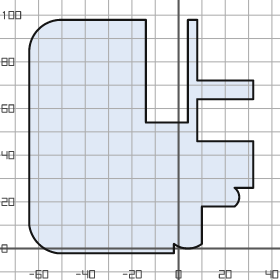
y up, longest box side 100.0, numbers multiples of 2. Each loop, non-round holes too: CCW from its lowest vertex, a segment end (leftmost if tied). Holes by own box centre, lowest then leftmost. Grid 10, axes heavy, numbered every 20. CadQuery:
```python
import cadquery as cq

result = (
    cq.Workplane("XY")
    .moveTo(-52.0, -2.0)
    .lineTo(-2.0, -2.0)
    .lineTo(-2.0, 2.0)
    .threePointArc((4.0, 0.0), (10.0, 2.0))
    .lineTo(10.0, 18.0)
    .lineTo(24.0, 18.0)
    .threePointArc((26.0, 22.0), (24.0, 26.0))
    .lineTo(32.0, 26.0)
    .lineTo(32.0, 46.0)
    .lineTo(8.0, 46.0)
    .lineTo(8.0, 64.0)
    .lineTo(32.0, 64.0)
    .lineTo(32.0, 72.0)
    .lineTo(8.0, 72.0)
    .lineTo(8.0, 98.0)
    .lineTo(4.0, 98.0)
    .lineTo(4.0, 54.0)
    .lineTo(-14.0, 54.0)
    .lineTo(-14.0, 98.0)
    .lineTo(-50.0, 98.0)
    .threePointArc((-60.0, 94.0), (-64.0, 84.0))
    .lineTo(-64.0, 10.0)
    .threePointArc((-60.0, 2.0), (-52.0, -2.0))
    .close()
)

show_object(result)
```